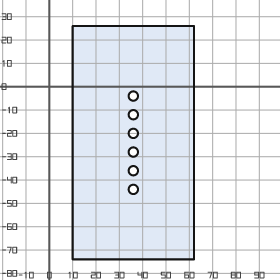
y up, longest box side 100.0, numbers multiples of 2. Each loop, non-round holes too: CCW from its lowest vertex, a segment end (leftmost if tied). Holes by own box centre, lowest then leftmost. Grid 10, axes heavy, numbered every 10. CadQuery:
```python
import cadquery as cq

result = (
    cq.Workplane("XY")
    .moveTo(10.0, -74.0)
    .lineTo(62.0, -74.0)
    .lineTo(62.0, 26.0)
    .lineTo(10.0, 26.0)
    .close()
    .moveTo(36.0, -44.0)
    .circle(2.0)
    .moveTo(36.0, -36.0)
    .circle(2.0)
    .moveTo(36.0, -28.0)
    .circle(2.0)
    .moveTo(36.0, -20.0)
    .circle(2.0)
    .moveTo(36.0, -12.0)
    .circle(2.0)
    .moveTo(36.0, -4.0)
    .circle(2.0)
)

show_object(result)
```